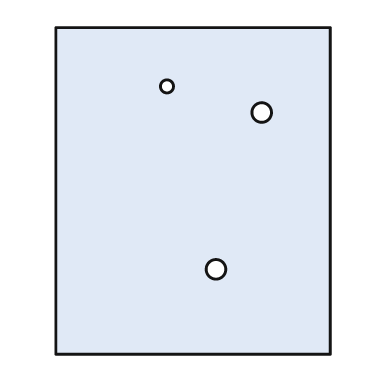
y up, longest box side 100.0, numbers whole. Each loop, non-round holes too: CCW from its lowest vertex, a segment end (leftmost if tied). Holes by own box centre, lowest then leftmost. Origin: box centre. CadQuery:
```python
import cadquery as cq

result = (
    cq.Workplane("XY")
    .moveTo(-42.0, -50.0)
    .lineTo(42.0, -50.0)
    .lineTo(42.0, 50.0)
    .lineTo(-42.0, 50.0)
    .close()
    .moveTo(7.0, -24.0)
    .circle(3.0)
    .moveTo(21.0, 24.0)
    .circle(3.0)
    .moveTo(-8.0, 32.0)
    .circle(2.0)
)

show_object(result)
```